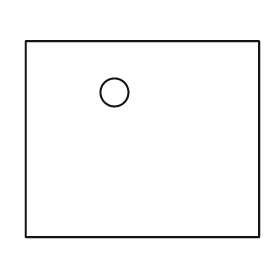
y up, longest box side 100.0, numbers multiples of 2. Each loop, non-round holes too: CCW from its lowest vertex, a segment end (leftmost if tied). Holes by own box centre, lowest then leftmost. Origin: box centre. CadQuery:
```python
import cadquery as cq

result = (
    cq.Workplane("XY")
    .moveTo(-50.0, -42.0)
    .lineTo(50.0, -42.0)
    .lineTo(50.0, 42.0)
    .lineTo(-50.0, 42.0)
    .close()
    .moveTo(-12.0, 20.0)
    .circle(6.0)
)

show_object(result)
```